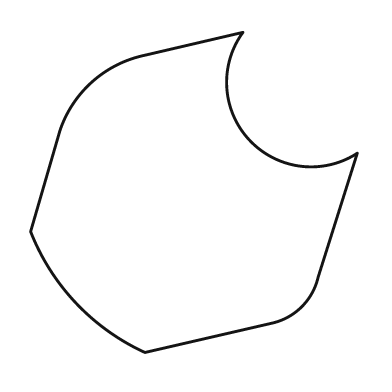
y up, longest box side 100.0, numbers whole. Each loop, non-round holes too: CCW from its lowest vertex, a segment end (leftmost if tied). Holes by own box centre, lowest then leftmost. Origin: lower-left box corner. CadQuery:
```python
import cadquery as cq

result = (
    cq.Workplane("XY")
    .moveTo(35.0, 0.0)
    .lineTo(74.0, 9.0)
    .threePointArc((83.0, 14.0), (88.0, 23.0))
    .lineTo(100.0, 61.0)
    .threePointArc((67.0, 65.0), (65.0, 98.0))
    .lineTo(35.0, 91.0)
    .threePointArc((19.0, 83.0), (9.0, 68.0))
    .lineTo(0.0, 37.0)
    .threePointArc((14.0, 15.0), (35.0, 0.0))
    .close()
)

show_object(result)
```